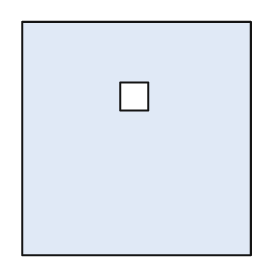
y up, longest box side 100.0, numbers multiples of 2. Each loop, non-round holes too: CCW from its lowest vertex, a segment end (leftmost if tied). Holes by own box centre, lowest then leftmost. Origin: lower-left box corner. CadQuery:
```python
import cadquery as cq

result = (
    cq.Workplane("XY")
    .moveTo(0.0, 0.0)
    .lineTo(98.0, 0.0)
    .lineTo(98.0, 100.0)
    .lineTo(0.0, 100.0)
    .close()
    .moveTo(42.0, 62.0)
    .lineTo(54.0, 62.0)
    .lineTo(54.0, 74.0)
    .lineTo(42.0, 74.0)
    .close()
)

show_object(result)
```